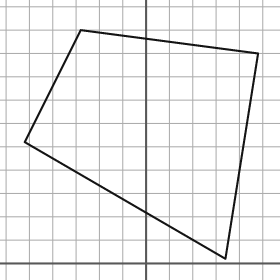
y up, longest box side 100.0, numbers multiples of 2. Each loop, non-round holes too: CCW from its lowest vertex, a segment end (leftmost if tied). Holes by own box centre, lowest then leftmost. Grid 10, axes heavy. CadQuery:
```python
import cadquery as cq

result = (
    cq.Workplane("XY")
    .moveTo(34.0, 2.0)
    .lineTo(48.0, 90.0)
    .lineTo(-28.0, 100.0)
    .lineTo(-52.0, 52.0)
    .close()
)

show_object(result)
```